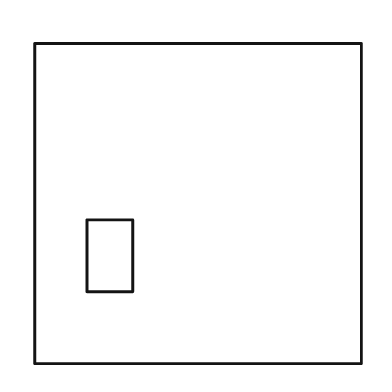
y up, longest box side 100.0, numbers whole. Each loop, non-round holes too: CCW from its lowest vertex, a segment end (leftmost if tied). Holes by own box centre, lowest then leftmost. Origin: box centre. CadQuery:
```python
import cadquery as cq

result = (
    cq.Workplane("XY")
    .moveTo(-50.0, -49.0)
    .lineTo(50.0, -49.0)
    .lineTo(50.0, 49.0)
    .lineTo(-50.0, 49.0)
    .close()
    .moveTo(-34.0, -27.0)
    .lineTo(-20.0, -27.0)
    .lineTo(-20.0, -5.0)
    .lineTo(-34.0, -5.0)
    .close()
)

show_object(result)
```